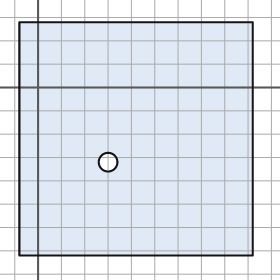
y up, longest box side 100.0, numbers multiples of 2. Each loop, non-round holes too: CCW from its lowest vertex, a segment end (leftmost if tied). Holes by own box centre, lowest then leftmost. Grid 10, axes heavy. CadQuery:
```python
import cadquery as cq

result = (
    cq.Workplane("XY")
    .moveTo(-8.0, -72.0)
    .lineTo(92.0, -72.0)
    .lineTo(92.0, 28.0)
    .lineTo(-8.0, 28.0)
    .close()
    .moveTo(30.0, -32.0)
    .circle(4.0)
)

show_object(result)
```